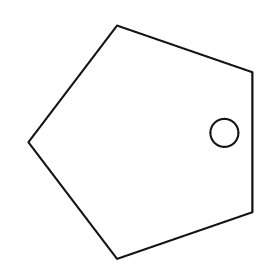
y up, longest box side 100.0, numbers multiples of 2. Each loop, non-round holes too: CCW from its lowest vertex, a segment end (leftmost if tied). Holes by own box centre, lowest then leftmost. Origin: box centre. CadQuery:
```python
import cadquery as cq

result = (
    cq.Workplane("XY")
    .moveTo(-10.0, -50.0)
    .lineTo(48.0, -30.0)
    .lineTo(48.0, 30.0)
    .lineTo(-10.0, 50.0)
    .lineTo(-48.0, 0.0)
    .close()
    .moveTo(36.0, 4.0)
    .circle(6.0)
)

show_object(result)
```